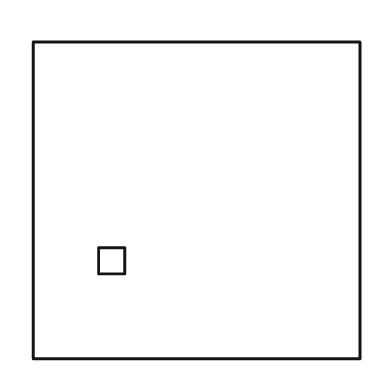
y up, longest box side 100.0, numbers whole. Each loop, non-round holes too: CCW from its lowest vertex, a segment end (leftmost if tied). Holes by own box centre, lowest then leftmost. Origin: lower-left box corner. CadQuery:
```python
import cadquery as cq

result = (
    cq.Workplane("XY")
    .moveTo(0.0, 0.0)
    .lineTo(100.0, 0.0)
    .lineTo(100.0, 97.0)
    .lineTo(0.0, 97.0)
    .close()
    .moveTo(20.0, 26.0)
    .lineTo(28.0, 26.0)
    .lineTo(28.0, 34.0)
    .lineTo(20.0, 34.0)
    .close()
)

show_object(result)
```